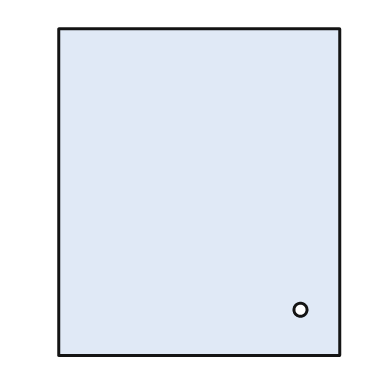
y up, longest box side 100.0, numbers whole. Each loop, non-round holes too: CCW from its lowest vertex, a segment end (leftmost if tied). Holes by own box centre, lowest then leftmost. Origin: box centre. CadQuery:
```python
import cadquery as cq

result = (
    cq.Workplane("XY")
    .moveTo(-43.0, -50.0)
    .lineTo(43.0, -50.0)
    .lineTo(43.0, 50.0)
    .lineTo(-43.0, 50.0)
    .close()
    .moveTo(31.0, -36.0)
    .circle(2.0)
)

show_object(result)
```